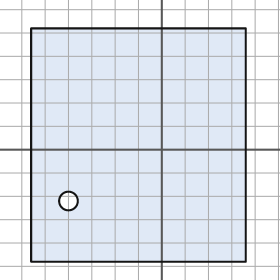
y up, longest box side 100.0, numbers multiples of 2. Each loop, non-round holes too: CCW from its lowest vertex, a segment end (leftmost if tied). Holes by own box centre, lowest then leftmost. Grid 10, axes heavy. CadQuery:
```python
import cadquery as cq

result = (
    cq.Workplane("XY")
    .moveTo(-56.0, -48.0)
    .lineTo(36.0, -48.0)
    .lineTo(36.0, 52.0)
    .lineTo(-56.0, 52.0)
    .close()
    .moveTo(-40.0, -22.0)
    .circle(4.0)
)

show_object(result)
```